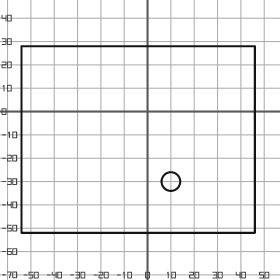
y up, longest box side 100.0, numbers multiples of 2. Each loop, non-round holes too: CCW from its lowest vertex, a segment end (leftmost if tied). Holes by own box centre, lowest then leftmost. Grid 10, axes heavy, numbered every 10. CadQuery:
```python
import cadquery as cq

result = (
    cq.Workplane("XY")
    .moveTo(-54.0, -52.0)
    .lineTo(46.0, -52.0)
    .lineTo(46.0, 28.0)
    .lineTo(-54.0, 28.0)
    .close()
    .moveTo(10.0, -30.0)
    .circle(4.0)
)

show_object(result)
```